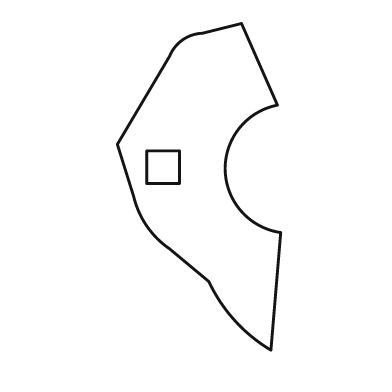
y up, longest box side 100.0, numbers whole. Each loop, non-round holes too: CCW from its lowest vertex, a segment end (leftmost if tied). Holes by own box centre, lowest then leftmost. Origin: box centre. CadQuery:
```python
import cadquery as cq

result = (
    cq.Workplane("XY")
    .moveTo(22.0, -50.0)
    .lineTo(25.0, -14.0)
    .threePointArc((8.0, 5.0), (24.0, 25.0))
    .lineTo(13.0, 50.0)
    .lineTo(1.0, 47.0)
    .threePointArc((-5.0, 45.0), (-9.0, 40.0))
    .lineTo(-25.0, 13.0)
    .lineTo(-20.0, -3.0)
    .threePointArc((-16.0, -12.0), (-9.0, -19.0))
    .lineTo(3.0, -29.0)
    .threePointArc((11.0, -41.0), (22.0, -50.0))
    .close()
    .moveTo(-16.0, 1.0)
    .lineTo(-6.0, 1.0)
    .lineTo(-6.0, 11.0)
    .lineTo(-16.0, 11.0)
    .close()
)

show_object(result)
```